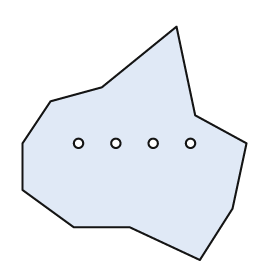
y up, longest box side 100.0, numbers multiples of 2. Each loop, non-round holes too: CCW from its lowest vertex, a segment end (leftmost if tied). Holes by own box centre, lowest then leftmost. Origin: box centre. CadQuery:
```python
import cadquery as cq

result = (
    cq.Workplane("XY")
    .moveTo(28.0, -50.0)
    .lineTo(42.0, -28.0)
    .lineTo(48.0, 0.0)
    .lineTo(26.0, 12.0)
    .lineTo(18.0, 50.0)
    .lineTo(-14.0, 24.0)
    .lineTo(-36.0, 18.0)
    .lineTo(-48.0, 0.0)
    .lineTo(-48.0, -20.0)
    .lineTo(-26.0, -36.0)
    .lineTo(-2.0, -36.0)
    .close()
    .moveTo(-24.0, 0.0)
    .circle(2.0)
    .moveTo(-8.0, 0.0)
    .circle(2.0)
    .moveTo(8.0, 0.0)
    .circle(2.0)
    .moveTo(24.0, 0.0)
    .circle(2.0)
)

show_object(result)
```